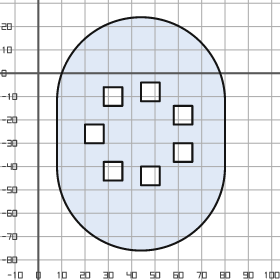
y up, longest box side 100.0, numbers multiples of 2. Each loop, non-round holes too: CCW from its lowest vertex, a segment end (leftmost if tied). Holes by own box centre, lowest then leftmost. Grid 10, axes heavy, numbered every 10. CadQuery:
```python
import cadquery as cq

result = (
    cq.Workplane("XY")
    .moveTo(8.0, -40.0)
    .threePointArc((44.0, -76.0), (80.0, -40.0))
    .lineTo(80.0, -12.0)
    .threePointArc((44.0, 24.0), (8.0, -12.0))
    .close()
    .moveTo(44.0, -48.0)
    .lineTo(52.0, -48.0)
    .lineTo(52.0, -40.0)
    .lineTo(44.0, -40.0)
    .close()
    .moveTo(28.0, -46.0)
    .lineTo(36.0, -46.0)
    .lineTo(36.0, -38.0)
    .lineTo(28.0, -38.0)
    .close()
    .moveTo(58.0, -38.0)
    .lineTo(66.0, -38.0)
    .lineTo(66.0, -30.0)
    .lineTo(58.0, -30.0)
    .close()
    .moveTo(20.0, -30.0)
    .lineTo(28.0, -30.0)
    .lineTo(28.0, -22.0)
    .lineTo(20.0, -22.0)
    .close()
    .moveTo(58.0, -22.0)
    .lineTo(66.0, -22.0)
    .lineTo(66.0, -14.0)
    .lineTo(58.0, -14.0)
    .close()
    .moveTo(28.0, -14.0)
    .lineTo(36.0, -14.0)
    .lineTo(36.0, -6.0)
    .lineTo(28.0, -6.0)
    .close()
    .moveTo(44.0, -12.0)
    .lineTo(52.0, -12.0)
    .lineTo(52.0, -4.0)
    .lineTo(44.0, -4.0)
    .close()
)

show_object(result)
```